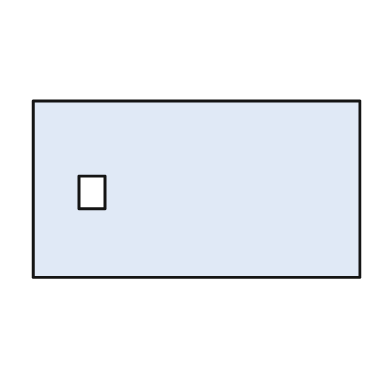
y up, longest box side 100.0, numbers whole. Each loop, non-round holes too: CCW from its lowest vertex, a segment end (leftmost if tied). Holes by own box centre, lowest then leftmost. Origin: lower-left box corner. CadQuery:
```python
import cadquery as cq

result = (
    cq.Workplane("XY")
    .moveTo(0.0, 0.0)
    .lineTo(100.0, 0.0)
    .lineTo(100.0, 54.0)
    .lineTo(0.0, 54.0)
    .close()
    .moveTo(14.0, 21.0)
    .lineTo(22.0, 21.0)
    .lineTo(22.0, 31.0)
    .lineTo(14.0, 31.0)
    .close()
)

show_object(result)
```